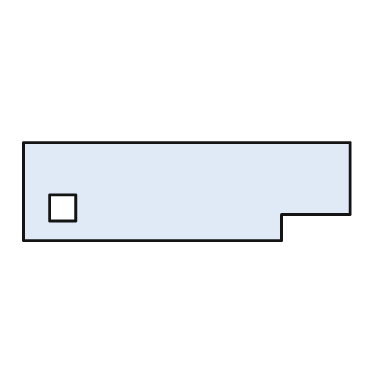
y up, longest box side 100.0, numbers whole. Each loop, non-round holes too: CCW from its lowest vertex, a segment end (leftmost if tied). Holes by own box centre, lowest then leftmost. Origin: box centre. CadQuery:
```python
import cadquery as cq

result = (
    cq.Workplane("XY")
    .moveTo(-50.0, -15.0)
    .lineTo(29.0, -15.0)
    .lineTo(29.0, -7.0)
    .lineTo(50.0, -7.0)
    .lineTo(50.0, 15.0)
    .lineTo(-50.0, 15.0)
    .close()
    .moveTo(-42.0, -9.0)
    .lineTo(-34.0, -9.0)
    .lineTo(-34.0, -1.0)
    .lineTo(-42.0, -1.0)
    .close()
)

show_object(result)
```